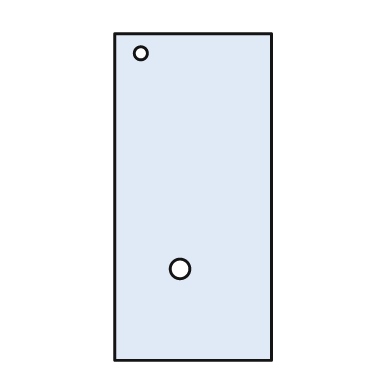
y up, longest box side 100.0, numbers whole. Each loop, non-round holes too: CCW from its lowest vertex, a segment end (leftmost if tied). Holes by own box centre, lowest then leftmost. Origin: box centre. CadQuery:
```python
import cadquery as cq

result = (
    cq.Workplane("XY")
    .moveTo(-24.0, -50.0)
    .lineTo(24.0, -50.0)
    .lineTo(24.0, 50.0)
    .lineTo(-24.0, 50.0)
    .close()
    .moveTo(-4.0, -22.0)
    .circle(3.0)
    .moveTo(-16.0, 44.0)
    .circle(2.0)
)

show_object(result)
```